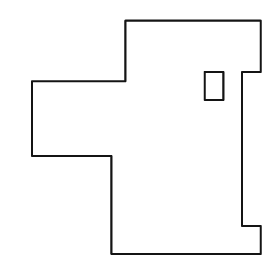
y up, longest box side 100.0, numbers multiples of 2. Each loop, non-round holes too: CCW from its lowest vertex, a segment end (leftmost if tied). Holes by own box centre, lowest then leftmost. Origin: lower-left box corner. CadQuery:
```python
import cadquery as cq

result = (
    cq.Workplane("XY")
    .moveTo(34.0, 0.0)
    .lineTo(98.0, 0.0)
    .lineTo(98.0, 12.0)
    .lineTo(90.0, 12.0)
    .lineTo(90.0, 78.0)
    .lineTo(98.0, 78.0)
    .lineTo(98.0, 100.0)
    .lineTo(40.0, 100.0)
    .lineTo(40.0, 74.0)
    .lineTo(0.0, 74.0)
    .lineTo(0.0, 42.0)
    .lineTo(34.0, 42.0)
    .close()
    .moveTo(74.0, 66.0)
    .lineTo(82.0, 66.0)
    .lineTo(82.0, 78.0)
    .lineTo(74.0, 78.0)
    .close()
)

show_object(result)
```